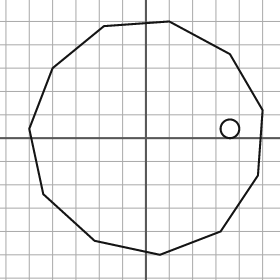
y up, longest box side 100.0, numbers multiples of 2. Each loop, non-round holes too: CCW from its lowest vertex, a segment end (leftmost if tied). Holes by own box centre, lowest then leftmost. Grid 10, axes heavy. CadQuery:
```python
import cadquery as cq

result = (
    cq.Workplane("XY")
    .moveTo(6.0, -50.0)
    .lineTo(32.0, -40.0)
    .lineTo(48.0, -16.0)
    .lineTo(50.0, 12.0)
    .lineTo(36.0, 36.0)
    .lineTo(10.0, 50.0)
    .lineTo(-18.0, 48.0)
    .lineTo(-40.0, 30.0)
    .lineTo(-50.0, 4.0)
    .lineTo(-44.0, -24.0)
    .lineTo(-22.0, -44.0)
    .close()
    .moveTo(36.0, 4.0)
    .circle(4.0)
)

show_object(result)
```